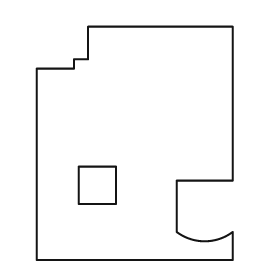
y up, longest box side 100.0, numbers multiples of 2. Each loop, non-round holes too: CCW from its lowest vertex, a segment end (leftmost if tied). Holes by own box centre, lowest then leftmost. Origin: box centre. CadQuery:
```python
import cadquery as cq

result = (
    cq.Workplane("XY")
    .moveTo(-42.0, -50.0)
    .lineTo(42.0, -50.0)
    .lineTo(42.0, -38.0)
    .threePointArc((30.0, -42.0), (18.0, -38.0))
    .lineTo(18.0, -16.0)
    .lineTo(42.0, -16.0)
    .lineTo(42.0, 50.0)
    .lineTo(-20.0, 50.0)
    .lineTo(-20.0, 36.0)
    .lineTo(-26.0, 36.0)
    .lineTo(-26.0, 32.0)
    .lineTo(-42.0, 32.0)
    .close()
    .moveTo(-24.0, -26.0)
    .lineTo(-8.0, -26.0)
    .lineTo(-8.0, -10.0)
    .lineTo(-24.0, -10.0)
    .close()
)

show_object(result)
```